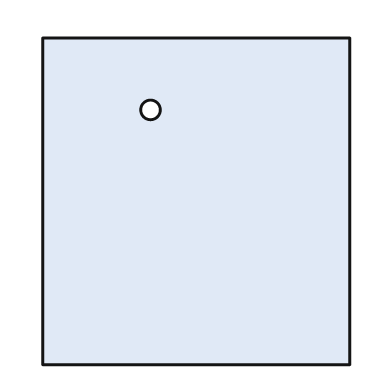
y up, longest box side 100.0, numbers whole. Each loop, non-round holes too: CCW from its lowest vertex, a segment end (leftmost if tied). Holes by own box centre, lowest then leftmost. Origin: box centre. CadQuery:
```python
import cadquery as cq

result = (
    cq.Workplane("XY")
    .moveTo(-47.0, -50.0)
    .lineTo(47.0, -50.0)
    .lineTo(47.0, 50.0)
    .lineTo(-47.0, 50.0)
    .close()
    .moveTo(-14.0, 28.0)
    .circle(3.0)
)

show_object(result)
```